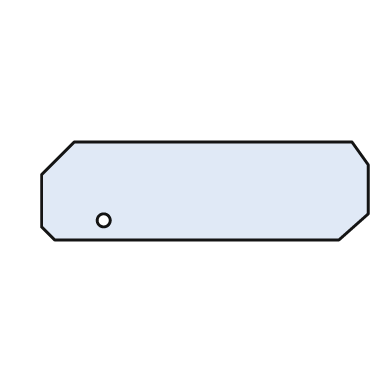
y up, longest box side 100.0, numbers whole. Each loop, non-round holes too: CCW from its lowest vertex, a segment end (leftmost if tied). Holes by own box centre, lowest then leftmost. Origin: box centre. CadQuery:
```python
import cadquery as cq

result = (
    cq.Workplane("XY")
    .moveTo(-46.0, -15.0)
    .lineTo(41.0, -15.0)
    .lineTo(50.0, -7.0)
    .lineTo(50.0, 8.0)
    .lineTo(45.0, 15.0)
    .lineTo(-40.0, 15.0)
    .lineTo(-50.0, 5.0)
    .lineTo(-50.0, -11.0)
    .close()
    .moveTo(-31.0, -9.0)
    .circle(2.0)
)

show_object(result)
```